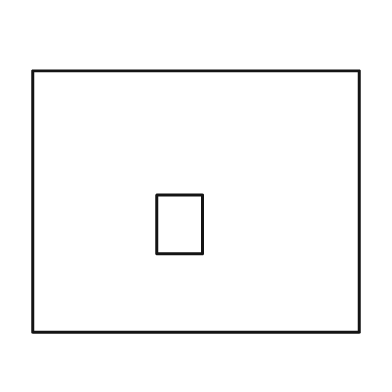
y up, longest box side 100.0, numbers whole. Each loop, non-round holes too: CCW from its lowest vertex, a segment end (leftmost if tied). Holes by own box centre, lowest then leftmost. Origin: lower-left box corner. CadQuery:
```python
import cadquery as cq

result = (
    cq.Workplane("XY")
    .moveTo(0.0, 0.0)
    .lineTo(100.0, 0.0)
    .lineTo(100.0, 80.0)
    .lineTo(0.0, 80.0)
    .close()
    .moveTo(38.0, 24.0)
    .lineTo(52.0, 24.0)
    .lineTo(52.0, 42.0)
    .lineTo(38.0, 42.0)
    .close()
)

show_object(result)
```